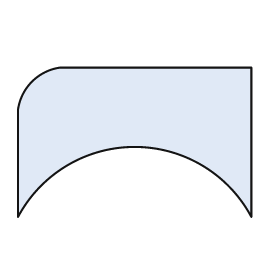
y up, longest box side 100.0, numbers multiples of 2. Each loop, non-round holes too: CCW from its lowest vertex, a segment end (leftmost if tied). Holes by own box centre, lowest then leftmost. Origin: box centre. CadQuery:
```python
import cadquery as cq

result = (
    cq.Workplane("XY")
    .moveTo(-50.0, -32.0)
    .threePointArc((0.0, -2.0), (50.0, -32.0))
    .lineTo(50.0, 32.0)
    .lineTo(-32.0, 32.0)
    .threePointArc((-44.0, 26.0), (-50.0, 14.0))
    .close()
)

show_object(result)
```